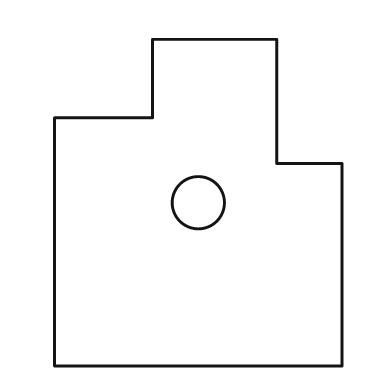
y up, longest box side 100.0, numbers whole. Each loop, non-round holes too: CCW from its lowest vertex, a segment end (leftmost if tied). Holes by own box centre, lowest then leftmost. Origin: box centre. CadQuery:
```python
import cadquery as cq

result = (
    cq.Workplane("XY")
    .moveTo(-44.0, -50.0)
    .lineTo(44.0, -50.0)
    .lineTo(44.0, 12.0)
    .lineTo(24.0, 12.0)
    .lineTo(24.0, 50.0)
    .lineTo(-14.0, 50.0)
    .lineTo(-14.0, 26.0)
    .lineTo(-44.0, 26.0)
    .close()
    .moveTo(0.0, 0.0)
    .circle(8.0)
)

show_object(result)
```